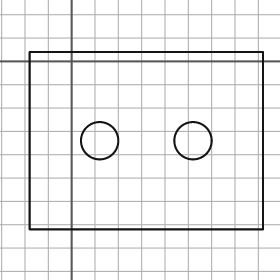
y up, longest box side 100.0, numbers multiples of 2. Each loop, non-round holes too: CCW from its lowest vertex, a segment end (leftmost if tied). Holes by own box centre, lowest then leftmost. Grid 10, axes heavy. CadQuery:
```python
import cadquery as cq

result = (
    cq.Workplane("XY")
    .moveTo(-18.0, -72.0)
    .lineTo(82.0, -72.0)
    .lineTo(82.0, 4.0)
    .lineTo(-18.0, 4.0)
    .close()
    .moveTo(12.0, -34.0)
    .circle(8.0)
    .moveTo(52.0, -34.0)
    .circle(8.0)
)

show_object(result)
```